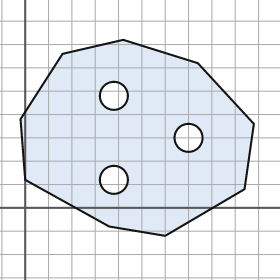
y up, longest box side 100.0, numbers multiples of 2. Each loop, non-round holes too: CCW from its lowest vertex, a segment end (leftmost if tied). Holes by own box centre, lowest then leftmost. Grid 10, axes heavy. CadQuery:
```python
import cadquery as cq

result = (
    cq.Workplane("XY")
    .moveTo(60.0, -12.0)
    .lineTo(94.0, 8.0)
    .lineTo(98.0, 36.0)
    .lineTo(74.0, 62.0)
    .lineTo(42.0, 72.0)
    .lineTo(16.0, 66.0)
    .lineTo(-2.0, 38.0)
    .lineTo(0.0, 12.0)
    .lineTo(36.0, -8.0)
    .close()
    .moveTo(38.0, 12.0)
    .circle(6.0)
    .moveTo(70.0, 30.0)
    .circle(6.0)
    .moveTo(38.0, 48.0)
    .circle(6.0)
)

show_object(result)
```